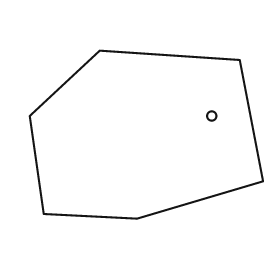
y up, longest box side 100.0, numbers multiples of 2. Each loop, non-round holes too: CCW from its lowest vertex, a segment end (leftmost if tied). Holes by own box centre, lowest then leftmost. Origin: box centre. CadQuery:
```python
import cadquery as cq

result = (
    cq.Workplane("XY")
    .moveTo(-4.0, -36.0)
    .lineTo(50.0, -20.0)
    .lineTo(40.0, 32.0)
    .lineTo(-20.0, 36.0)
    .lineTo(-50.0, 8.0)
    .lineTo(-44.0, -34.0)
    .close()
    .moveTo(28.0, 8.0)
    .circle(2.0)
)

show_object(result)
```